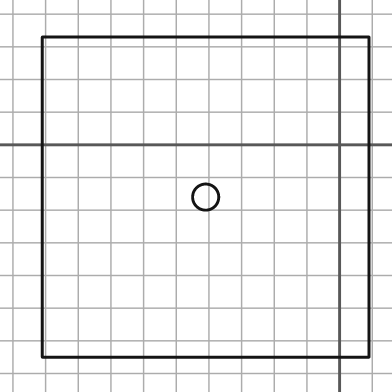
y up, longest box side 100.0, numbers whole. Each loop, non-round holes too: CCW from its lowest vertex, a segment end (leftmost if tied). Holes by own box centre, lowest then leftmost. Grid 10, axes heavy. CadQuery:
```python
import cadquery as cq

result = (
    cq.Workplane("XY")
    .moveTo(-91.0, -65.0)
    .lineTo(9.0, -65.0)
    .lineTo(9.0, 33.0)
    .lineTo(-91.0, 33.0)
    .close()
    .moveTo(-41.0, -16.0)
    .circle(4.0)
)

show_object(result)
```